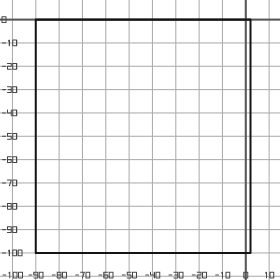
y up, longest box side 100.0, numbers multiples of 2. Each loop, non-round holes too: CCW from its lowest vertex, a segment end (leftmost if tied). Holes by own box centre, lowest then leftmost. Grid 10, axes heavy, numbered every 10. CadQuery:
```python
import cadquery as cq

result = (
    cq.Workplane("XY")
    .moveTo(-90.0, -100.0)
    .lineTo(2.0, -100.0)
    .lineTo(2.0, 0.0)
    .lineTo(-90.0, 0.0)
    .close()
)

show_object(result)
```